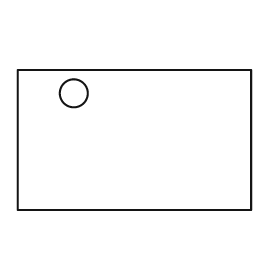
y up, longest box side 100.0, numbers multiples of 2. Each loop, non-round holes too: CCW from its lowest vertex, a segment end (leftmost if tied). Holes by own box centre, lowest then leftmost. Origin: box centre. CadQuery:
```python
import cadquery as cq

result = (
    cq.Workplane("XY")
    .moveTo(-50.0, -30.0)
    .lineTo(50.0, -30.0)
    .lineTo(50.0, 30.0)
    .lineTo(-50.0, 30.0)
    .close()
    .moveTo(-26.0, 20.0)
    .circle(6.0)
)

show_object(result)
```